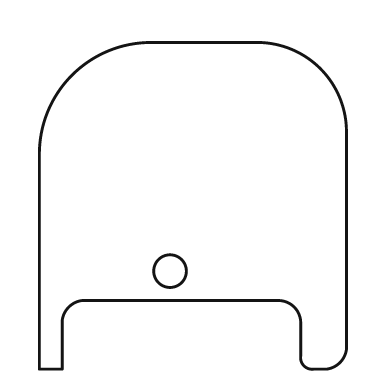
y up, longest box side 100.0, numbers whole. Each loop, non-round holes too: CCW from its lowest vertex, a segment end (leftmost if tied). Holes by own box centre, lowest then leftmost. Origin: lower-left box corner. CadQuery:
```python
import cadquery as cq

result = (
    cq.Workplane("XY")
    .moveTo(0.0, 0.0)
    .lineTo(7.0, 0.0)
    .lineTo(7.0, 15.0)
    .threePointArc((9.0, 19.0), (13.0, 21.0))
    .lineTo(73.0, 21.0)
    .threePointArc((78.0, 19.0), (80.0, 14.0))
    .lineTo(80.0, 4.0)
    .threePointArc((81.0, 1.0), (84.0, 0.0))
    .lineTo(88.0, 0.0)
    .threePointArc((92.0, 2.0), (94.0, 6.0))
    .lineTo(94.0, 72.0)
    .threePointArc((86.0, 92.0), (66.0, 100.0))
    .lineTo(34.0, 100.0)
    .threePointArc((10.0, 90.0), (0.0, 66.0))
    .close()
    .moveTo(40.0, 30.0)
    .circle(5.0)
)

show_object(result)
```